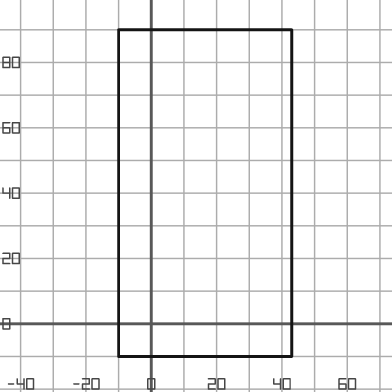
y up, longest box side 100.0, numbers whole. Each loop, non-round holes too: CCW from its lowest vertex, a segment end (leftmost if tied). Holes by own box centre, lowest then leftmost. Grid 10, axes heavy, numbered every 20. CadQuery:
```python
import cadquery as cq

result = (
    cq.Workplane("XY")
    .moveTo(-10.0, -10.0)
    .lineTo(43.0, -10.0)
    .lineTo(43.0, 90.0)
    .lineTo(-10.0, 90.0)
    .close()
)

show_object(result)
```